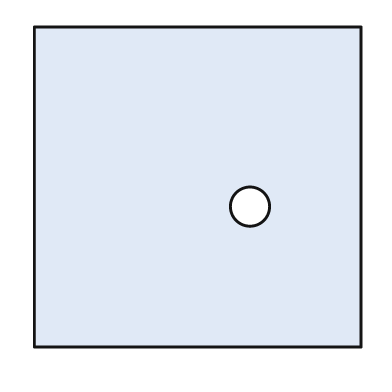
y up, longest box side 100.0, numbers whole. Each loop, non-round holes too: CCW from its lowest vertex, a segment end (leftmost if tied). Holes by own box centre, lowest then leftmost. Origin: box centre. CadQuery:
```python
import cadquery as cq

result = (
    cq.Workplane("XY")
    .moveTo(-50.0, -49.0)
    .lineTo(50.0, -49.0)
    .lineTo(50.0, 49.0)
    .lineTo(-50.0, 49.0)
    .close()
    .moveTo(16.0, -6.0)
    .circle(6.0)
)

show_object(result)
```